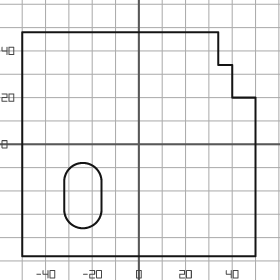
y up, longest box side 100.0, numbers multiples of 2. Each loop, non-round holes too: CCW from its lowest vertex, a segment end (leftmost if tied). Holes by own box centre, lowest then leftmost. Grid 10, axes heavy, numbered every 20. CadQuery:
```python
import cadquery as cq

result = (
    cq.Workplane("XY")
    .moveTo(-50.0, -48.0)
    .lineTo(50.0, -48.0)
    .lineTo(50.0, 20.0)
    .lineTo(40.0, 20.0)
    .lineTo(40.0, 34.0)
    .lineTo(34.0, 34.0)
    .lineTo(34.0, 48.0)
    .lineTo(-50.0, 48.0)
    .close()
    .moveTo(-32.0, -28.0)
    .threePointArc((-24.0, -36.0), (-16.0, -28.0))
    .lineTo(-16.0, -16.0)
    .threePointArc((-24.0, -8.0), (-32.0, -16.0))
    .close()
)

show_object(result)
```